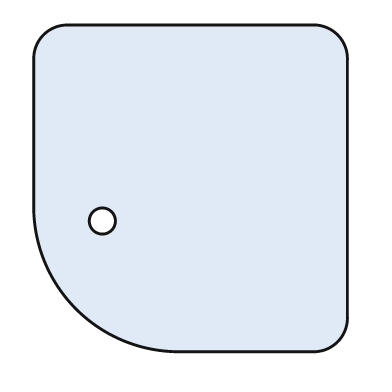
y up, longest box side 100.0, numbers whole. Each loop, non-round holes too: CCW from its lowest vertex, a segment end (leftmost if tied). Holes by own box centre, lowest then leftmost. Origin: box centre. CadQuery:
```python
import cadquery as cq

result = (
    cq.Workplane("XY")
    .moveTo(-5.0, -50.0)
    .lineTo(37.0, -50.0)
    .threePointArc((45.0, -47.0), (48.0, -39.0))
    .lineTo(48.0, 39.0)
    .threePointArc((45.0, 47.0), (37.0, 50.0))
    .lineTo(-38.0, 50.0)
    .threePointArc((-45.0, 47.0), (-48.0, 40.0))
    .lineTo(-48.0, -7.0)
    .threePointArc((-35.0, -37.0), (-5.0, -50.0))
    .close()
    .moveTo(-27.0, -10.0)
    .circle(4.0)
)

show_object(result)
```